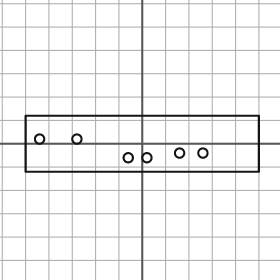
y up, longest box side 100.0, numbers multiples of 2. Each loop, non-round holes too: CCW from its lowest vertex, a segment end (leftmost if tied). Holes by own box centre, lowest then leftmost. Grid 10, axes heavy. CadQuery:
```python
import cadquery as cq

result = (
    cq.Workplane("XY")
    .moveTo(-50.0, -12.0)
    .lineTo(50.0, -12.0)
    .lineTo(50.0, 12.0)
    .lineTo(-50.0, 12.0)
    .close()
    .moveTo(-6.0, -6.0)
    .circle(2.0)
    .moveTo(2.0, -6.0)
    .circle(2.0)
    .moveTo(16.0, -4.0)
    .circle(2.0)
    .moveTo(26.0, -4.0)
    .circle(2.0)
    .moveTo(-44.0, 2.0)
    .circle(2.0)
    .moveTo(-28.0, 2.0)
    .circle(2.0)
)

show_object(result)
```